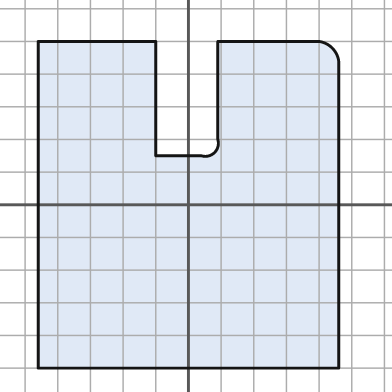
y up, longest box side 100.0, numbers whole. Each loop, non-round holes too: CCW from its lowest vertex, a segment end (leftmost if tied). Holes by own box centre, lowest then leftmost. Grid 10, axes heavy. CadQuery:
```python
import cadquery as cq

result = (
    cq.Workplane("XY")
    .moveTo(-46.0, -50.0)
    .lineTo(46.0, -50.0)
    .lineTo(46.0, 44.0)
    .threePointArc((44.0, 48.0), (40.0, 50.0))
    .lineTo(9.0, 50.0)
    .lineTo(9.0, 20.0)
    .threePointArc((8.0, 16.0), (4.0, 15.0))
    .lineTo(-10.0, 15.0)
    .lineTo(-10.0, 50.0)
    .lineTo(-46.0, 50.0)
    .close()
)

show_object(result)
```